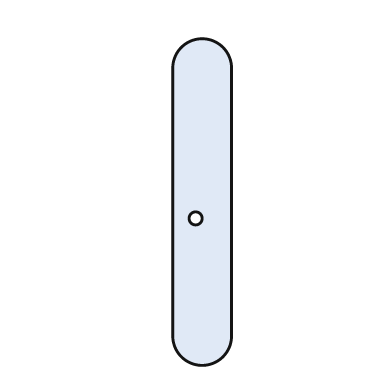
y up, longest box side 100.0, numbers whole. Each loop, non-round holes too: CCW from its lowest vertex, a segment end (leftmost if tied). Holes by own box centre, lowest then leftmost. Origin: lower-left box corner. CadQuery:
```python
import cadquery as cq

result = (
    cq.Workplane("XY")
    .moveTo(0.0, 9.0)
    .threePointArc((9.0, 0.0), (18.0, 9.0))
    .lineTo(18.0, 91.0)
    .threePointArc((9.0, 100.0), (0.0, 91.0))
    .close()
    .moveTo(7.0, 45.0)
    .circle(2.0)
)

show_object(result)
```